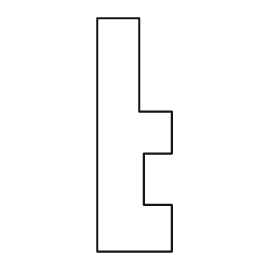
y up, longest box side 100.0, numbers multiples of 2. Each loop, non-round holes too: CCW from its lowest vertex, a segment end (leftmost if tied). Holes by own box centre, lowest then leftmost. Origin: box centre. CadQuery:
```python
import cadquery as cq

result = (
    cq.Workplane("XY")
    .moveTo(-16.0, -50.0)
    .lineTo(16.0, -50.0)
    .lineTo(16.0, -30.0)
    .lineTo(4.0, -30.0)
    .lineTo(4.0, -8.0)
    .lineTo(16.0, -8.0)
    .lineTo(16.0, 10.0)
    .lineTo(2.0, 10.0)
    .lineTo(2.0, 50.0)
    .lineTo(-16.0, 50.0)
    .close()
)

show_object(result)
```